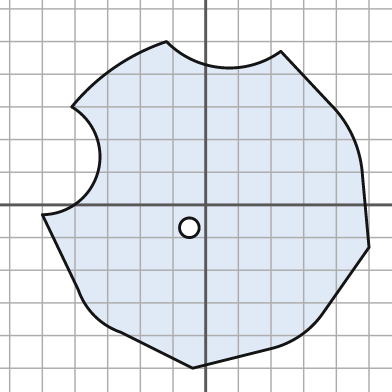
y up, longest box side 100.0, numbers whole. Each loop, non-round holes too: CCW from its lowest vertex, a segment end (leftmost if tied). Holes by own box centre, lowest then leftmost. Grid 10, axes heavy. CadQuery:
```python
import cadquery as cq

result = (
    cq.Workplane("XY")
    .moveTo(-4.0, -50.0)
    .lineTo(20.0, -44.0)
    .threePointArc((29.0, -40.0), (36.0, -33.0))
    .lineTo(50.0, -13.0)
    .lineTo(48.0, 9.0)
    .threePointArc((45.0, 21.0), (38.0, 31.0))
    .lineTo(23.0, 47.0)
    .threePointArc((5.0, 42.0), (-12.0, 50.0))
    .threePointArc((-28.0, 42.0), (-41.0, 30.0))
    .threePointArc((-33.0, 10.0), (-50.0, -3.0))
    .lineTo(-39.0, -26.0)
    .threePointArc((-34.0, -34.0), (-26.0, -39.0))
    .close()
    .moveTo(-5.0, -7.0)
    .circle(3.0)
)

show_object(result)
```